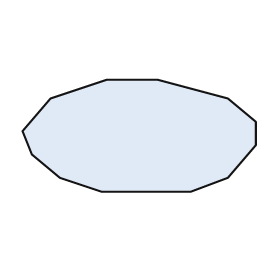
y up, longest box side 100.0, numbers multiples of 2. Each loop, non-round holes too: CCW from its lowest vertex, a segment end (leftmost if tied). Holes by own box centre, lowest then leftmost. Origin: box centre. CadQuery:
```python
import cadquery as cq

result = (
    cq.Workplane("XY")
    .moveTo(-16.0, -24.0)
    .lineTo(22.0, -24.0)
    .lineTo(38.0, -18.0)
    .lineTo(50.0, -4.0)
    .lineTo(50.0, 6.0)
    .lineTo(38.0, 16.0)
    .lineTo(8.0, 24.0)
    .lineTo(-14.0, 24.0)
    .lineTo(-38.0, 16.0)
    .lineTo(-50.0, 2.0)
    .lineTo(-46.0, -8.0)
    .lineTo(-34.0, -18.0)
    .close()
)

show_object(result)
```